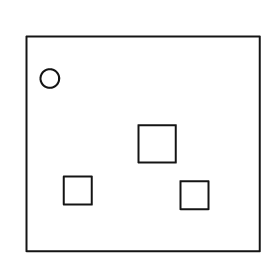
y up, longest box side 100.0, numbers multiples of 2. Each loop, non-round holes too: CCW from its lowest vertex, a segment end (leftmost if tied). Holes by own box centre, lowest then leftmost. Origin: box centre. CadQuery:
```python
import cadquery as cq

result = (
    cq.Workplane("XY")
    .moveTo(-50.0, -46.0)
    .lineTo(50.0, -46.0)
    .lineTo(50.0, 46.0)
    .lineTo(-50.0, 46.0)
    .close()
    .moveTo(16.0, -28.0)
    .lineTo(28.0, -28.0)
    .lineTo(28.0, -16.0)
    .lineTo(16.0, -16.0)
    .close()
    .moveTo(-34.0, -26.0)
    .lineTo(-22.0, -26.0)
    .lineTo(-22.0, -14.0)
    .lineTo(-34.0, -14.0)
    .close()
    .moveTo(-2.0, -8.0)
    .lineTo(14.0, -8.0)
    .lineTo(14.0, 8.0)
    .lineTo(-2.0, 8.0)
    .close()
    .moveTo(-40.0, 28.0)
    .circle(4.0)
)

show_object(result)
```